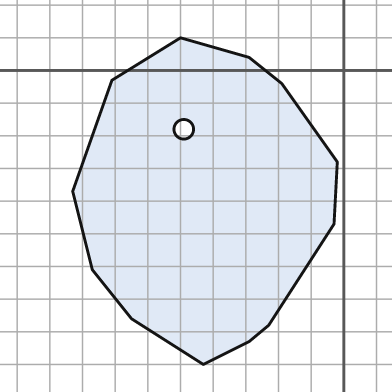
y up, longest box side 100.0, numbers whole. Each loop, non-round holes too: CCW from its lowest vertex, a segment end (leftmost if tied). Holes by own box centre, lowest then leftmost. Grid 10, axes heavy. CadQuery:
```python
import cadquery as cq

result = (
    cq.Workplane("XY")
    .moveTo(-43.0, -90.0)
    .lineTo(-29.0, -83.0)
    .lineTo(-23.0, -78.0)
    .lineTo(-3.0, -47.0)
    .lineTo(-2.0, -28.0)
    .lineTo(-19.0, -4.0)
    .lineTo(-29.0, 4.0)
    .lineTo(-50.0, 10.0)
    .lineTo(-71.0, -3.0)
    .lineTo(-83.0, -37.0)
    .lineTo(-77.0, -61.0)
    .lineTo(-65.0, -76.0)
    .close()
    .moveTo(-49.0, -18.0)
    .circle(3.0)
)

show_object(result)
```